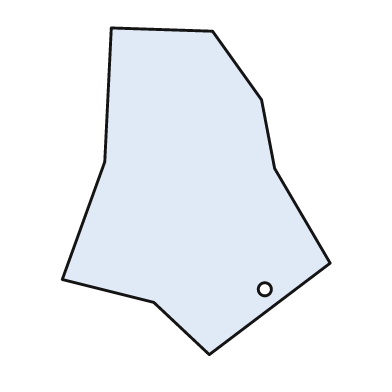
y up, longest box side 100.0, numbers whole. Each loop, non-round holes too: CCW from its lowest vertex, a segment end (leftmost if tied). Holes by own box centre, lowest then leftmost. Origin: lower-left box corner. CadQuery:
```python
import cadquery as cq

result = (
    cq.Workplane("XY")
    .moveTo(45.0, 0.0)
    .lineTo(82.0, 28.0)
    .lineTo(65.0, 57.0)
    .lineTo(61.0, 78.0)
    .lineTo(46.0, 99.0)
    .lineTo(15.0, 100.0)
    .lineTo(13.0, 59.0)
    .lineTo(0.0, 23.0)
    .lineTo(28.0, 16.0)
    .close()
    .moveTo(62.0, 20.0)
    .circle(2.0)
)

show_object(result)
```